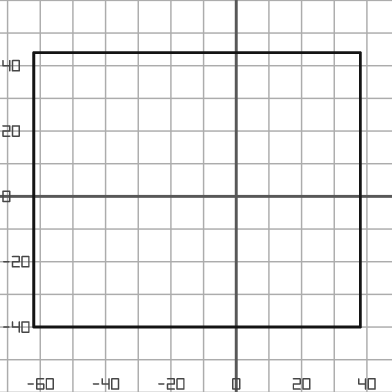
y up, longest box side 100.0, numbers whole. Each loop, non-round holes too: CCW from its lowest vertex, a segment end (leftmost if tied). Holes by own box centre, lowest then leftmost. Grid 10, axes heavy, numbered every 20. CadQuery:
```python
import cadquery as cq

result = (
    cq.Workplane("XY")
    .moveTo(-62.0, -40.0)
    .lineTo(38.0, -40.0)
    .lineTo(38.0, 44.0)
    .lineTo(-62.0, 44.0)
    .close()
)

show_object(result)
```